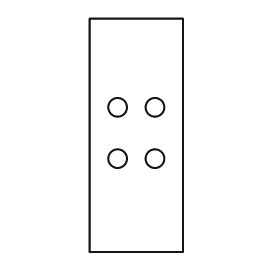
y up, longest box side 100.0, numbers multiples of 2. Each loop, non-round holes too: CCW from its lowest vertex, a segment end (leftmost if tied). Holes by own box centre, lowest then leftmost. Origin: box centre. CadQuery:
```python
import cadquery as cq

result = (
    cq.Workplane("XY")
    .moveTo(-20.0, -50.0)
    .lineTo(20.0, -50.0)
    .lineTo(20.0, 50.0)
    .lineTo(-20.0, 50.0)
    .close()
    .moveTo(-8.0, -10.0)
    .circle(4.0)
    .moveTo(8.0, -10.0)
    .circle(4.0)
    .moveTo(-8.0, 12.0)
    .circle(4.0)
    .moveTo(8.0, 12.0)
    .circle(4.0)
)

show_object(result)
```